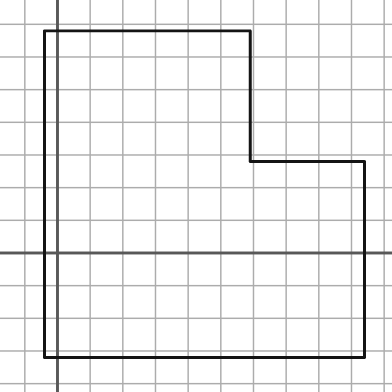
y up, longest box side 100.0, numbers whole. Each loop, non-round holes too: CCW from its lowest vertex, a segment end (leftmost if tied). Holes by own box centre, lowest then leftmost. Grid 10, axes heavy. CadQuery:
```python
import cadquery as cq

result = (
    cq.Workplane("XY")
    .moveTo(-4.0, -32.0)
    .lineTo(94.0, -32.0)
    .lineTo(94.0, 28.0)
    .lineTo(59.0, 28.0)
    .lineTo(59.0, 68.0)
    .lineTo(-4.0, 68.0)
    .close()
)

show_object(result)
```